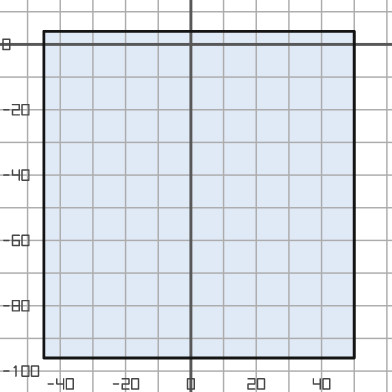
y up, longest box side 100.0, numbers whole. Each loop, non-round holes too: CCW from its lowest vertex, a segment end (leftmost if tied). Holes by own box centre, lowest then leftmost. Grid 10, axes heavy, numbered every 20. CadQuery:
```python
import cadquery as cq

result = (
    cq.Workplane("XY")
    .moveTo(-45.0, -96.0)
    .lineTo(50.0, -96.0)
    .lineTo(50.0, 4.0)
    .lineTo(-45.0, 4.0)
    .close()
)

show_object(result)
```